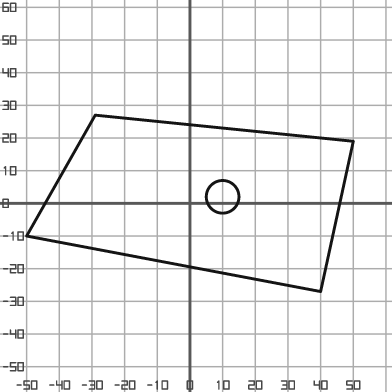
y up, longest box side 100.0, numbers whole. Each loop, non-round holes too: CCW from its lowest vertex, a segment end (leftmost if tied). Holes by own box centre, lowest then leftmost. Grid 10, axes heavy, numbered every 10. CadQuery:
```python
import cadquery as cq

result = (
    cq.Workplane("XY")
    .moveTo(40.0, -27.0)
    .lineTo(50.0, 19.0)
    .lineTo(-29.0, 27.0)
    .lineTo(-50.0, -10.0)
    .close()
    .moveTo(10.0, 2.0)
    .circle(5.0)
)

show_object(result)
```